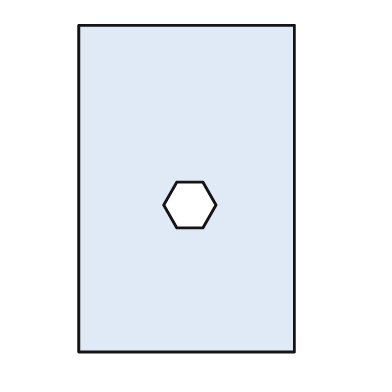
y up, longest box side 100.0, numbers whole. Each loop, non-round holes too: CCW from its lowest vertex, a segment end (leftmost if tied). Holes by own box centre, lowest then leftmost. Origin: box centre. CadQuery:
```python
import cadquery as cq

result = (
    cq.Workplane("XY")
    .moveTo(-33.0, -50.0)
    .lineTo(33.0, -50.0)
    .lineTo(33.0, 50.0)
    .lineTo(-33.0, 50.0)
    .close()
    .moveTo(-3.0, -12.0)
    .lineTo(5.0, -12.0)
    .lineTo(9.0, -5.0)
    .lineTo(5.0, 2.0)
    .lineTo(-3.0, 2.0)
    .lineTo(-7.0, -5.0)
    .close()
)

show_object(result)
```